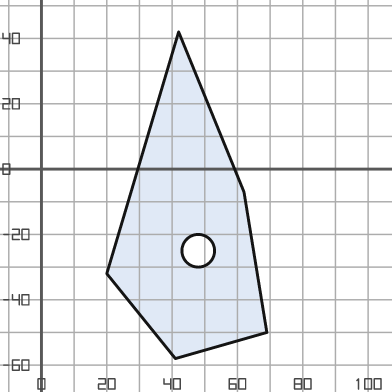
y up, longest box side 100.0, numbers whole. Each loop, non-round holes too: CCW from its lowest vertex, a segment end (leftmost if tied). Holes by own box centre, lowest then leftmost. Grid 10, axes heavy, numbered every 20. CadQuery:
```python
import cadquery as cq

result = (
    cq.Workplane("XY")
    .moveTo(41.0, -58.0)
    .lineTo(69.0, -50.0)
    .lineTo(62.0, -7.0)
    .lineTo(42.0, 42.0)
    .lineTo(20.0, -32.0)
    .close()
    .moveTo(48.0, -25.0)
    .circle(5.0)
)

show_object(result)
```